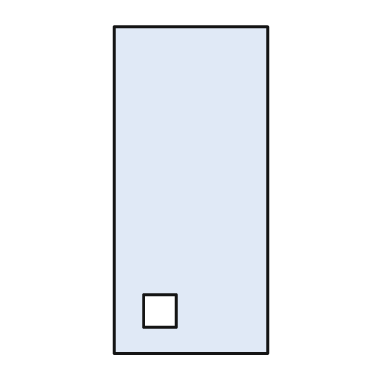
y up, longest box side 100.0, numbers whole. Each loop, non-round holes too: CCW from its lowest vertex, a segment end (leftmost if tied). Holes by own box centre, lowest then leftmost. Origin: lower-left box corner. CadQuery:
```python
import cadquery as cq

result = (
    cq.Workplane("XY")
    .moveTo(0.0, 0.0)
    .lineTo(47.0, 0.0)
    .lineTo(47.0, 100.0)
    .lineTo(0.0, 100.0)
    .close()
    .moveTo(9.0, 8.0)
    .lineTo(19.0, 8.0)
    .lineTo(19.0, 18.0)
    .lineTo(9.0, 18.0)
    .close()
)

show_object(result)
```